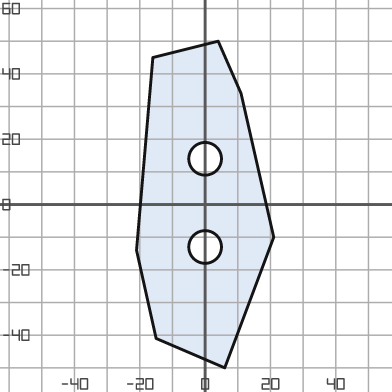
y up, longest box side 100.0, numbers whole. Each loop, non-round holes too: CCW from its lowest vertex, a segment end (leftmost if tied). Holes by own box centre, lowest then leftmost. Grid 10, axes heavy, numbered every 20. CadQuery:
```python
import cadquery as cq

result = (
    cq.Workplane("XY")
    .moveTo(6.0, -50.0)
    .lineTo(21.0, -10.0)
    .lineTo(11.0, 34.0)
    .lineTo(4.0, 50.0)
    .lineTo(-16.0, 45.0)
    .lineTo(-21.0, -14.0)
    .lineTo(-15.0, -41.0)
    .close()
    .moveTo(0.0, -13.0)
    .circle(5.0)
    .moveTo(0.0, 14.0)
    .circle(5.0)
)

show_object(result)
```